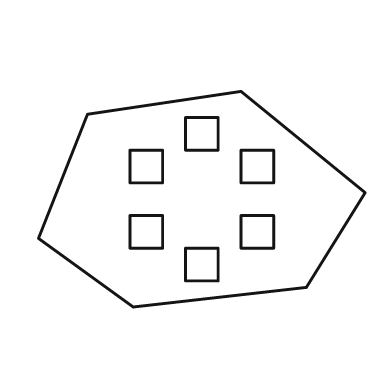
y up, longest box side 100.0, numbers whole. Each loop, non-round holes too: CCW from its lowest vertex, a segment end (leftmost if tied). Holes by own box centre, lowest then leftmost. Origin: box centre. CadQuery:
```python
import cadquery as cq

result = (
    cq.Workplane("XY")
    .moveTo(-21.0, -33.0)
    .lineTo(32.0, -27.0)
    .lineTo(50.0, 2.0)
    .lineTo(12.0, 33.0)
    .lineTo(-35.0, 26.0)
    .lineTo(-50.0, -12.0)
    .close()
    .moveTo(-5.0, -25.0)
    .lineTo(5.0, -25.0)
    .lineTo(5.0, -15.0)
    .lineTo(-5.0, -15.0)
    .close()
    .moveTo(-22.0, -15.0)
    .lineTo(-12.0, -15.0)
    .lineTo(-12.0, -5.0)
    .lineTo(-22.0, -5.0)
    .close()
    .moveTo(12.0, -15.0)
    .lineTo(22.0, -15.0)
    .lineTo(22.0, -5.0)
    .lineTo(12.0, -5.0)
    .close()
    .moveTo(-22.0, 5.0)
    .lineTo(-12.0, 5.0)
    .lineTo(-12.0, 15.0)
    .lineTo(-22.0, 15.0)
    .close()
    .moveTo(12.0, 5.0)
    .lineTo(22.0, 5.0)
    .lineTo(22.0, 15.0)
    .lineTo(12.0, 15.0)
    .close()
    .moveTo(-5.0, 15.0)
    .lineTo(5.0, 15.0)
    .lineTo(5.0, 25.0)
    .lineTo(-5.0, 25.0)
    .close()
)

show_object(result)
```